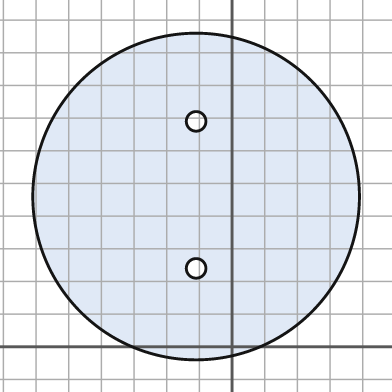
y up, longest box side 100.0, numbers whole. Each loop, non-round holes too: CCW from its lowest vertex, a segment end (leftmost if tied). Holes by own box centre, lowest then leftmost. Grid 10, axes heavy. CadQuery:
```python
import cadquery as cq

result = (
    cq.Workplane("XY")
    .moveTo(-11.0, 46.0)
    .circle(50.0)
    .moveTo(-11.0, 24.0)
    .circle(3.0)
    .moveTo(-11.0, 69.0)
    .circle(3.0)
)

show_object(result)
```